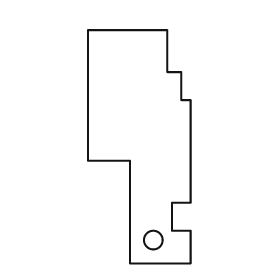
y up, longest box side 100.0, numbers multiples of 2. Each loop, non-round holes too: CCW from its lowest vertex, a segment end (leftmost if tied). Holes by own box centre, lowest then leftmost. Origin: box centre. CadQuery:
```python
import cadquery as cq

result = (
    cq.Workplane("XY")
    .moveTo(-4.0, -50.0)
    .lineTo(22.0, -50.0)
    .lineTo(22.0, -36.0)
    .lineTo(14.0, -36.0)
    .lineTo(14.0, -24.0)
    .lineTo(22.0, -24.0)
    .lineTo(22.0, 20.0)
    .lineTo(18.0, 20.0)
    .lineTo(18.0, 32.0)
    .lineTo(12.0, 32.0)
    .lineTo(12.0, 50.0)
    .lineTo(-22.0, 50.0)
    .lineTo(-22.0, -6.0)
    .lineTo(-4.0, -6.0)
    .close()
    .moveTo(6.0, -40.0)
    .circle(4.0)
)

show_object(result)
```